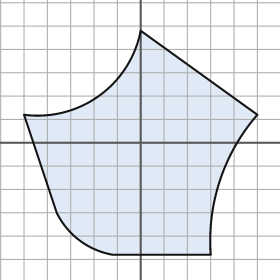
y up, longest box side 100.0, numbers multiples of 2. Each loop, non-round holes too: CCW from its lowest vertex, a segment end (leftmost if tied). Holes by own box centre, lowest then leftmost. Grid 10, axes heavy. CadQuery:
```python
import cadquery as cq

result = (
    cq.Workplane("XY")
    .moveTo(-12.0, -48.0)
    .lineTo(30.0, -48.0)
    .threePointArc((34.0, -16.0), (50.0, 12.0))
    .lineTo(0.0, 48.0)
    .threePointArc((-18.0, 20.0), (-50.0, 12.0))
    .lineTo(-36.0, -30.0)
    .threePointArc((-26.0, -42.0), (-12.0, -48.0))
    .close()
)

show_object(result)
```